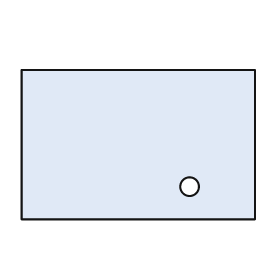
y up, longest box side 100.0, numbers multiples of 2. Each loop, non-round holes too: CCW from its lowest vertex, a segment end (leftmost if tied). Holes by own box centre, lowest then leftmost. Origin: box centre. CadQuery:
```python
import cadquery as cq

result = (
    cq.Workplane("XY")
    .moveTo(-50.0, -32.0)
    .lineTo(50.0, -32.0)
    .lineTo(50.0, 32.0)
    .lineTo(-50.0, 32.0)
    .close()
    .moveTo(22.0, -18.0)
    .circle(4.0)
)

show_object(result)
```